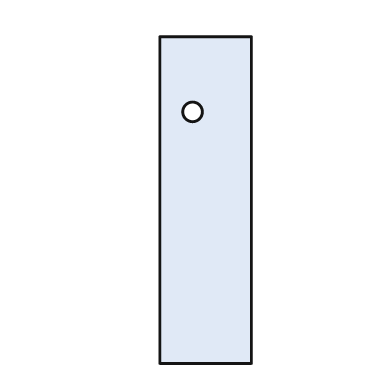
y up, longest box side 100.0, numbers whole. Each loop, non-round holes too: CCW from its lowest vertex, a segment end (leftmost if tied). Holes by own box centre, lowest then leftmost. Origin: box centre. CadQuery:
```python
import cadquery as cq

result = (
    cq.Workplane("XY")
    .moveTo(-14.0, -50.0)
    .lineTo(14.0, -50.0)
    .lineTo(14.0, 50.0)
    .lineTo(-14.0, 50.0)
    .close()
    .moveTo(-4.0, 27.0)
    .circle(3.0)
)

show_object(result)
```